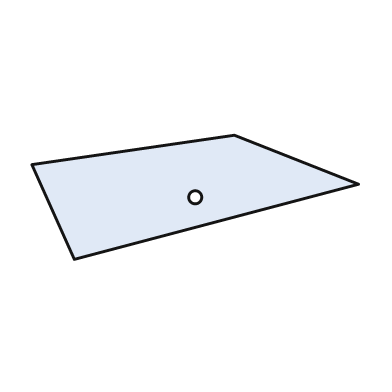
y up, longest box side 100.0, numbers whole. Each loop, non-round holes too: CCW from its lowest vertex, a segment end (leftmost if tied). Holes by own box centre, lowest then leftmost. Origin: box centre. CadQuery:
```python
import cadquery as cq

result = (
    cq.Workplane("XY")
    .moveTo(-37.0, -19.0)
    .lineTo(50.0, 4.0)
    .lineTo(12.0, 19.0)
    .lineTo(-50.0, 10.0)
    .close()
    .moveTo(0.0, 0.0)
    .circle(2.0)
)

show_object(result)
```